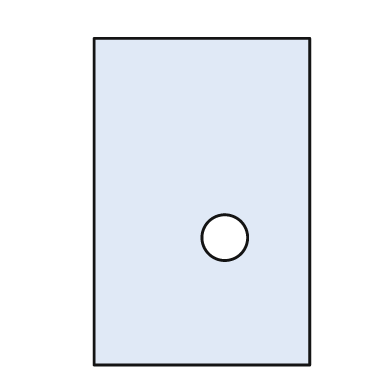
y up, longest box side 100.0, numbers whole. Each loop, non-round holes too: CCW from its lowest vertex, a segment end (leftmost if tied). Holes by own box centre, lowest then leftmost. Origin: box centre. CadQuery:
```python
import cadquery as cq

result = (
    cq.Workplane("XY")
    .moveTo(-33.0, -50.0)
    .lineTo(33.0, -50.0)
    .lineTo(33.0, 50.0)
    .lineTo(-33.0, 50.0)
    .close()
    .moveTo(7.0, -11.0)
    .circle(7.0)
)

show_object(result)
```